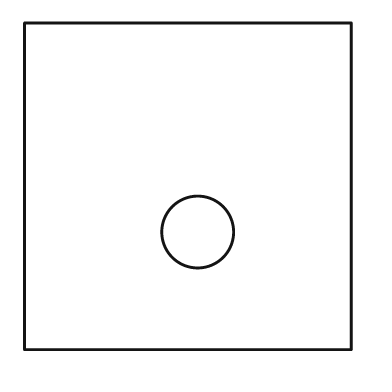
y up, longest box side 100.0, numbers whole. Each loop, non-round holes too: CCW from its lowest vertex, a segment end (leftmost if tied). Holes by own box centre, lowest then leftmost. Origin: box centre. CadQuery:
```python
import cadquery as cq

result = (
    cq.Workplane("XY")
    .moveTo(-50.0, -50.0)
    .lineTo(50.0, -50.0)
    .lineTo(50.0, 50.0)
    .lineTo(-50.0, 50.0)
    .close()
    .moveTo(3.0, -14.0)
    .circle(11.0)
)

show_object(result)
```